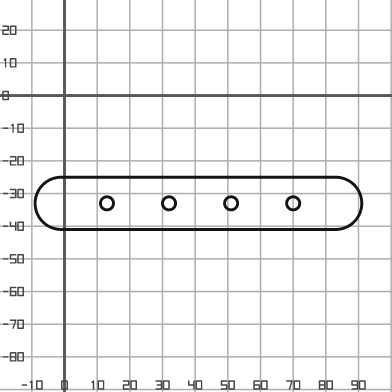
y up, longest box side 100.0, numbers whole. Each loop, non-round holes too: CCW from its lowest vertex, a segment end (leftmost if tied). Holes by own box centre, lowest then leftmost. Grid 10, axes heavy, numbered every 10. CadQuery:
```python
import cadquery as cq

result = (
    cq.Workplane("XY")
    .moveTo(-1.0, -41.0)
    .lineTo(83.0, -41.0)
    .threePointArc((91.0, -33.0), (83.0, -25.0))
    .lineTo(-1.0, -25.0)
    .threePointArc((-9.0, -33.0), (-1.0, -41.0))
    .close()
    .moveTo(13.0, -33.0)
    .circle(2.0)
    .moveTo(32.0, -33.0)
    .circle(2.0)
    .moveTo(51.0, -33.0)
    .circle(2.0)
    .moveTo(70.0, -33.0)
    .circle(2.0)
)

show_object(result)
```